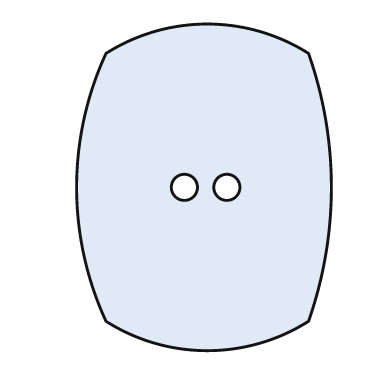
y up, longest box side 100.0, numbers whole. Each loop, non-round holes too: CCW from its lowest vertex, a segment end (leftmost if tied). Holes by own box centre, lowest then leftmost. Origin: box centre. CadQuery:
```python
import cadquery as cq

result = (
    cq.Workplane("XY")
    .moveTo(-30.0, -41.0)
    .threePointArc((1.0, -50.0), (32.0, -41.0))
    .threePointArc((39.0, 0.0), (32.0, 41.0))
    .threePointArc((1.0, 50.0), (-30.0, 41.0))
    .threePointArc((-39.0, 0.0), (-30.0, -41.0))
    .close()
    .moveTo(-6.0, 0.0)
    .circle(4.0)
    .moveTo(7.0, 0.0)
    .circle(4.0)
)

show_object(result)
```